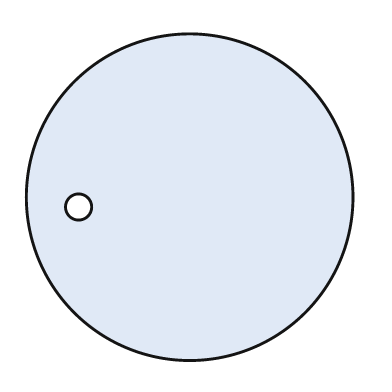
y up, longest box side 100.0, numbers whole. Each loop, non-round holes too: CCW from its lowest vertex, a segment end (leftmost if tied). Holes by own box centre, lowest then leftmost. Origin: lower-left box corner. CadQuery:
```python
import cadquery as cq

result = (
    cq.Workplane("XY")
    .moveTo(50.0, 50.0)
    .circle(50.0)
    .moveTo(16.0, 47.0)
    .circle(4.0)
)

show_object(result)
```